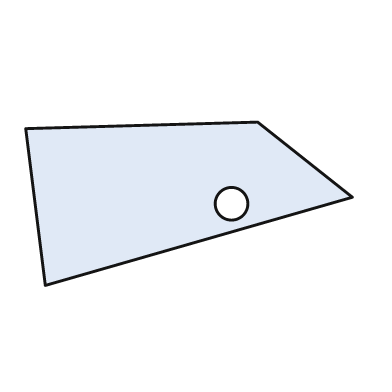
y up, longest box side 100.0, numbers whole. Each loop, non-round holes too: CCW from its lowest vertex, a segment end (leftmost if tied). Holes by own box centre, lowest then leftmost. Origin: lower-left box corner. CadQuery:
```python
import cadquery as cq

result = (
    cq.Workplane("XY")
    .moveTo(6.0, 0.0)
    .lineTo(100.0, 27.0)
    .lineTo(71.0, 50.0)
    .lineTo(0.0, 48.0)
    .close()
    .moveTo(63.0, 25.0)
    .circle(5.0)
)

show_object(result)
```